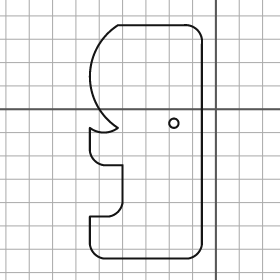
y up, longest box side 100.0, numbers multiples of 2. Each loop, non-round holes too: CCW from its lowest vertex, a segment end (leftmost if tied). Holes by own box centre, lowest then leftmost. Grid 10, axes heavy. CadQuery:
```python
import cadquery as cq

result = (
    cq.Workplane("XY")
    .moveTo(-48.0, -64.0)
    .lineTo(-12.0, -64.0)
    .threePointArc((-8.0, -62.0), (-6.0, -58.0))
    .lineTo(-6.0, 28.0)
    .threePointArc((-8.0, 34.0), (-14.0, 36.0))
    .lineTo(-42.0, 36.0)
    .threePointArc((-54.0, 14.0), (-42.0, -8.0))
    .threePointArc((-48.0, -10.0), (-54.0, -8.0))
    .lineTo(-54.0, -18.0)
    .threePointArc((-52.0, -22.0), (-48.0, -24.0))
    .lineTo(-40.0, -24.0)
    .lineTo(-40.0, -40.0)
    .threePointArc((-42.0, -44.0), (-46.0, -46.0))
    .lineTo(-54.0, -46.0)
    .lineTo(-54.0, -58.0)
    .threePointArc((-52.0, -62.0), (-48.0, -64.0))
    .close()
    .moveTo(-18.0, -6.0)
    .circle(2.0)
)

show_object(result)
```